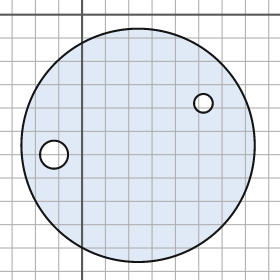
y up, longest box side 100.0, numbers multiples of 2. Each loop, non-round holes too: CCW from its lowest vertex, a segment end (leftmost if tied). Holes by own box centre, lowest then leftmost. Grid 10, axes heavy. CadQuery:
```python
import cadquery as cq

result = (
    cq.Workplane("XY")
    .moveTo(24.0, -56.0)
    .circle(50.0)
    .moveTo(-12.0, -60.0)
    .circle(6.0)
    .moveTo(52.0, -38.0)
    .circle(4.0)
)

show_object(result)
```